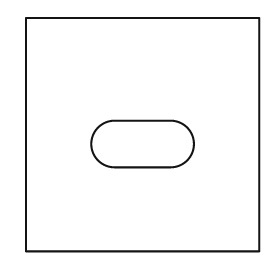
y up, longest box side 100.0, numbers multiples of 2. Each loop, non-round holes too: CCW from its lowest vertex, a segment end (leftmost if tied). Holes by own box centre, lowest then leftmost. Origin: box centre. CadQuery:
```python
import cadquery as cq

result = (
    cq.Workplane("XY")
    .moveTo(-50.0, -50.0)
    .lineTo(50.0, -50.0)
    .lineTo(50.0, 50.0)
    .lineTo(-50.0, 50.0)
    .close()
    .moveTo(-12.0, -14.0)
    .lineTo(12.0, -14.0)
    .threePointArc((22.0, -4.0), (12.0, 6.0))
    .lineTo(-12.0, 6.0)
    .threePointArc((-22.0, -4.0), (-12.0, -14.0))
    .close()
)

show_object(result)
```